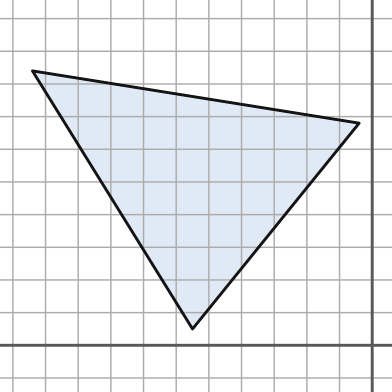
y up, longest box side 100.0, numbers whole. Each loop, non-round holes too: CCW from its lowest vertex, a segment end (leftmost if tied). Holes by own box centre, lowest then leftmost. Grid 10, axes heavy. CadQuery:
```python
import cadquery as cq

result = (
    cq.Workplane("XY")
    .moveTo(-55.0, 5.0)
    .lineTo(-4.0, 68.0)
    .lineTo(-104.0, 84.0)
    .close()
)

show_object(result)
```